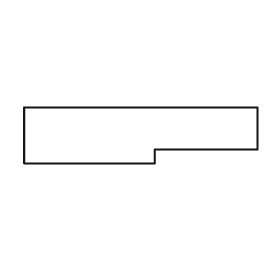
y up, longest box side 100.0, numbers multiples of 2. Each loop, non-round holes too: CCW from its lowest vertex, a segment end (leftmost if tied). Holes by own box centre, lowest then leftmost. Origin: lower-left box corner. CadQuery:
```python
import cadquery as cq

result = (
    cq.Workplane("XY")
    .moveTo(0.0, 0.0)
    .lineTo(56.0, 0.0)
    .lineTo(56.0, 6.0)
    .lineTo(100.0, 6.0)
    .lineTo(100.0, 24.0)
    .lineTo(0.0, 24.0)
    .close()
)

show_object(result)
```